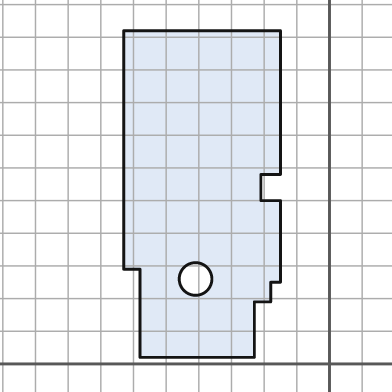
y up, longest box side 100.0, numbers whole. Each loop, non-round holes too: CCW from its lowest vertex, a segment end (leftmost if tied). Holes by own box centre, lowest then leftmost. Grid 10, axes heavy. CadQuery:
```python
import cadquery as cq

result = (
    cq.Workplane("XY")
    .moveTo(-58.0, 2.0)
    .lineTo(-23.0, 2.0)
    .lineTo(-23.0, 19.0)
    .lineTo(-18.0, 19.0)
    .lineTo(-18.0, 25.0)
    .lineTo(-15.0, 25.0)
    .lineTo(-15.0, 50.0)
    .lineTo(-21.0, 50.0)
    .lineTo(-21.0, 58.0)
    .lineTo(-15.0, 58.0)
    .lineTo(-15.0, 102.0)
    .lineTo(-63.0, 102.0)
    .lineTo(-63.0, 29.0)
    .lineTo(-58.0, 29.0)
    .close()
    .moveTo(-41.0, 26.0)
    .circle(5.0)
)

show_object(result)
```